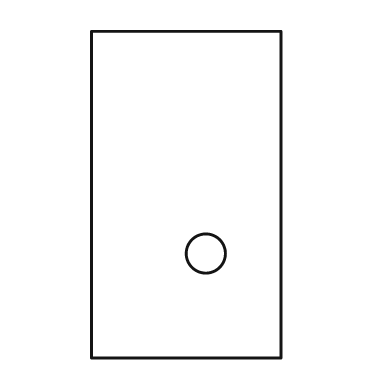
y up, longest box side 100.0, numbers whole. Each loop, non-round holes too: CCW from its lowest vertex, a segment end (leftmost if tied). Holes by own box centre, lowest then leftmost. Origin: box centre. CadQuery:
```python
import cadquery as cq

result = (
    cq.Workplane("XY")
    .moveTo(-29.0, -50.0)
    .lineTo(29.0, -50.0)
    .lineTo(29.0, 50.0)
    .lineTo(-29.0, 50.0)
    .close()
    .moveTo(6.0, -18.0)
    .circle(6.0)
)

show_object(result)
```